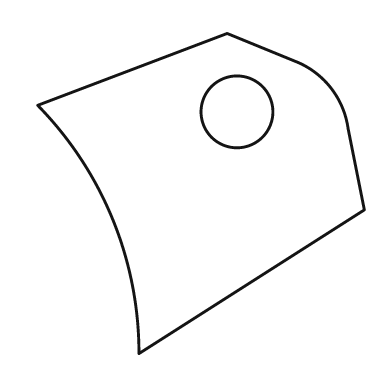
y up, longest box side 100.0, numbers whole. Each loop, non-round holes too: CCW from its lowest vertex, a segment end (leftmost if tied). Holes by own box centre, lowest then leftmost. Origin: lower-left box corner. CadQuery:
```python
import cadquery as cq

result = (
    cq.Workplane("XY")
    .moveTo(31.0, 0.0)
    .lineTo(100.0, 44.0)
    .lineTo(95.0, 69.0)
    .threePointArc((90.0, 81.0), (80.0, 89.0))
    .lineTo(58.0, 98.0)
    .lineTo(0.0, 76.0)
    .threePointArc((23.0, 41.0), (31.0, 0.0))
    .close()
    .moveTo(61.0, 74.0)
    .circle(11.0)
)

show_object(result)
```